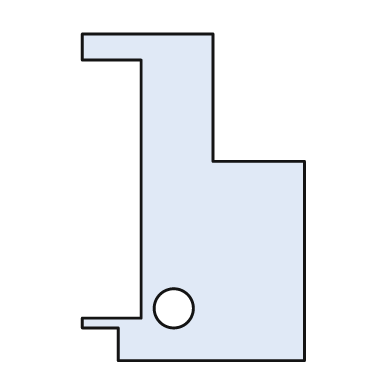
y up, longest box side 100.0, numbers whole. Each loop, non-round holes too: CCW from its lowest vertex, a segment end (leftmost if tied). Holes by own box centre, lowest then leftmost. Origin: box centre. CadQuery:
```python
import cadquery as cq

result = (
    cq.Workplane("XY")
    .moveTo(-23.0, -50.0)
    .lineTo(34.0, -50.0)
    .lineTo(34.0, 11.0)
    .lineTo(6.0, 11.0)
    .lineTo(6.0, 50.0)
    .lineTo(-34.0, 50.0)
    .lineTo(-34.0, 42.0)
    .lineTo(-16.0, 42.0)
    .lineTo(-16.0, -37.0)
    .lineTo(-34.0, -37.0)
    .lineTo(-34.0, -40.0)
    .lineTo(-23.0, -40.0)
    .close()
    .moveTo(-6.0, -34.0)
    .circle(6.0)
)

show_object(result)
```